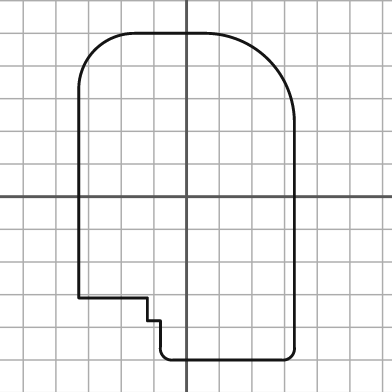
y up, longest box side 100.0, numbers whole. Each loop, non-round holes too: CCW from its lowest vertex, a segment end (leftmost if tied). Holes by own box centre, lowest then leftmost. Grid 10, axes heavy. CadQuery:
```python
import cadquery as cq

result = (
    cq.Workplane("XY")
    .moveTo(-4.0, -50.0)
    .lineTo(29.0, -50.0)
    .threePointArc((32.0, -49.0), (33.0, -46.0))
    .lineTo(33.0, 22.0)
    .threePointArc((25.0, 42.0), (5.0, 50.0))
    .lineTo(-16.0, 50.0)
    .threePointArc((-28.0, 45.0), (-33.0, 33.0))
    .lineTo(-33.0, -31.0)
    .lineTo(-12.0, -31.0)
    .lineTo(-12.0, -38.0)
    .lineTo(-8.0, -38.0)
    .lineTo(-8.0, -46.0)
    .threePointArc((-7.0, -49.0), (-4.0, -50.0))
    .close()
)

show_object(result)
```